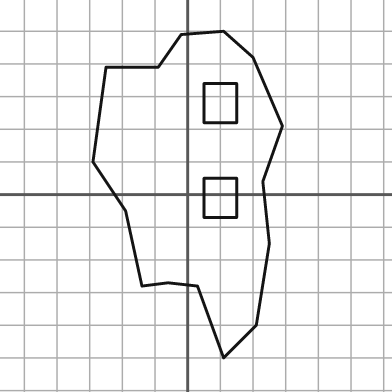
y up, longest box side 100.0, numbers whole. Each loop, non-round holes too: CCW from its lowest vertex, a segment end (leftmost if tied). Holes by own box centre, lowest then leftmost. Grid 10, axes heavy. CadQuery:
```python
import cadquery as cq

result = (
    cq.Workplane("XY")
    .moveTo(11.0, -50.0)
    .lineTo(21.0, -40.0)
    .lineTo(25.0, -15.0)
    .lineTo(23.0, 4.0)
    .lineTo(29.0, 21.0)
    .lineTo(20.0, 42.0)
    .lineTo(11.0, 50.0)
    .lineTo(-2.0, 49.0)
    .lineTo(-9.0, 39.0)
    .lineTo(-25.0, 39.0)
    .lineTo(-29.0, 10.0)
    .lineTo(-19.0, -5.0)
    .lineTo(-14.0, -28.0)
    .lineTo(-6.0, -27.0)
    .lineTo(3.0, -28.0)
    .close()
    .moveTo(5.0, -7.0)
    .lineTo(15.0, -7.0)
    .lineTo(15.0, 5.0)
    .lineTo(5.0, 5.0)
    .close()
    .moveTo(5.0, 22.0)
    .lineTo(15.0, 22.0)
    .lineTo(15.0, 34.0)
    .lineTo(5.0, 34.0)
    .close()
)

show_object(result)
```